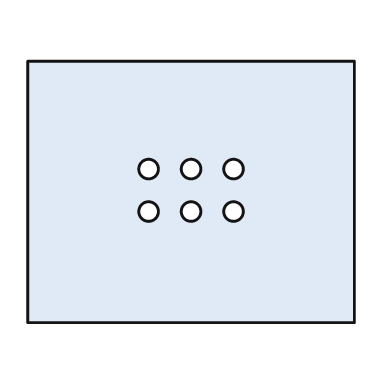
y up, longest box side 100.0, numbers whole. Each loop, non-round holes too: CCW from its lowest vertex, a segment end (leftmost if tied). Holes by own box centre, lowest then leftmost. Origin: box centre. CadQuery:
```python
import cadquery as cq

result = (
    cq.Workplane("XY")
    .moveTo(-50.0, -40.0)
    .lineTo(50.0, -40.0)
    .lineTo(50.0, 40.0)
    .lineTo(-50.0, 40.0)
    .close()
    .moveTo(-13.0, -6.0)
    .circle(3.0)
    .moveTo(0.0, -6.0)
    .circle(3.0)
    .moveTo(13.0, -6.0)
    .circle(3.0)
    .moveTo(-13.0, 7.0)
    .circle(3.0)
    .moveTo(0.0, 7.0)
    .circle(3.0)
    .moveTo(13.0, 7.0)
    .circle(3.0)
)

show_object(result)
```